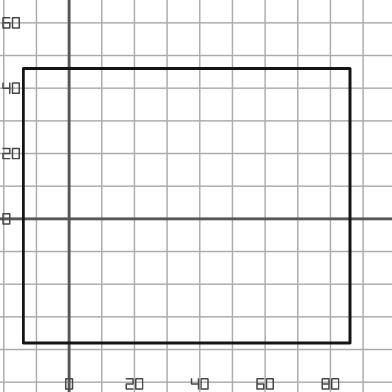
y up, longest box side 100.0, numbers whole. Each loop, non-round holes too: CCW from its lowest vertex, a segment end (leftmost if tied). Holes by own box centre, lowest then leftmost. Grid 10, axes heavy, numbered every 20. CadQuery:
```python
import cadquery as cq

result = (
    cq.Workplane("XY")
    .moveTo(-14.0, -38.0)
    .lineTo(86.0, -38.0)
    .lineTo(86.0, 46.0)
    .lineTo(-14.0, 46.0)
    .close()
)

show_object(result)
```